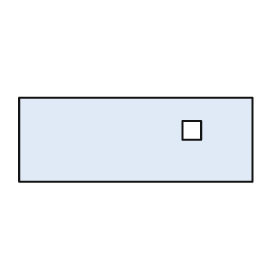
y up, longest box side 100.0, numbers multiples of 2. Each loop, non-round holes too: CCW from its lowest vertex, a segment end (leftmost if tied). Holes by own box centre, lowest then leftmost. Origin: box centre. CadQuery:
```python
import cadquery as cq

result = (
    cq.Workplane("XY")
    .moveTo(-50.0, -18.0)
    .lineTo(50.0, -18.0)
    .lineTo(50.0, 18.0)
    .lineTo(-50.0, 18.0)
    .close()
    .moveTo(20.0, 0.0)
    .lineTo(28.0, 0.0)
    .lineTo(28.0, 8.0)
    .lineTo(20.0, 8.0)
    .close()
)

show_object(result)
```